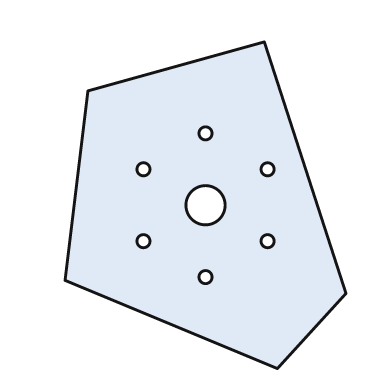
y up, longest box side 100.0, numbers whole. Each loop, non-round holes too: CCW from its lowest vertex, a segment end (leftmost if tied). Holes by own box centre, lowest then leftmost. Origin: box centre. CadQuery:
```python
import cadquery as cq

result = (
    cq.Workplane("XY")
    .moveTo(22.0, -50.0)
    .lineTo(43.0, -27.0)
    .lineTo(18.0, 50.0)
    .lineTo(-36.0, 35.0)
    .lineTo(-43.0, -23.0)
    .close()
    .moveTo(0.0, -22.0)
    .circle(2.0)
    .moveTo(-19.0, -11.0)
    .circle(2.0)
    .moveTo(19.0, -11.0)
    .circle(2.0)
    .moveTo(0.0, 0.0)
    .circle(6.0)
    .moveTo(-19.0, 11.0)
    .circle(2.0)
    .moveTo(19.0, 11.0)
    .circle(2.0)
    .moveTo(0.0, 22.0)
    .circle(2.0)
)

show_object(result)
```